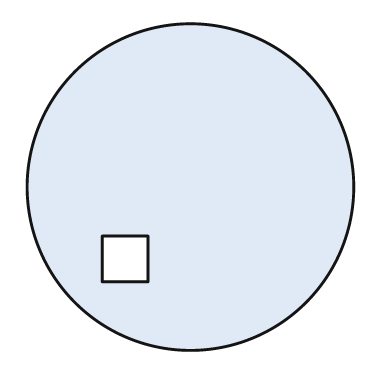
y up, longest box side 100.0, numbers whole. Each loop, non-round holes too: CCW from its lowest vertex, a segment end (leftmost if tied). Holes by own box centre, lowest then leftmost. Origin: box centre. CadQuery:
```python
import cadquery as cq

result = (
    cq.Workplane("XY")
    .moveTo(0.0, 0.0)
    .circle(50.0)
    .moveTo(-27.0, -29.0)
    .lineTo(-13.0, -29.0)
    .lineTo(-13.0, -15.0)
    .lineTo(-27.0, -15.0)
    .close()
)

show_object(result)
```